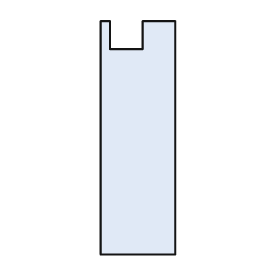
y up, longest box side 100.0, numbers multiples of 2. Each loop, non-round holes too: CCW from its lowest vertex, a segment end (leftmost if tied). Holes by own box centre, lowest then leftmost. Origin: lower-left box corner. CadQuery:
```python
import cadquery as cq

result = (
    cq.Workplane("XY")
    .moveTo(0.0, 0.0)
    .lineTo(32.0, 0.0)
    .lineTo(32.0, 100.0)
    .lineTo(18.0, 100.0)
    .lineTo(18.0, 88.0)
    .lineTo(4.0, 88.0)
    .lineTo(4.0, 100.0)
    .lineTo(0.0, 100.0)
    .close()
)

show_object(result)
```